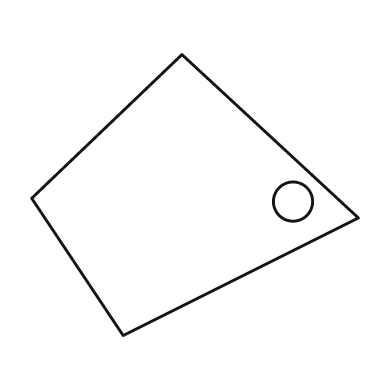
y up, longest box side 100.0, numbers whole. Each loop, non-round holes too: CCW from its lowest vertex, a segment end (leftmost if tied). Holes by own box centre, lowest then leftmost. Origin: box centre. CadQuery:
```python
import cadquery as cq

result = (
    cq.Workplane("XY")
    .moveTo(-22.0, -43.0)
    .lineTo(50.0, -7.0)
    .lineTo(-4.0, 43.0)
    .lineTo(-50.0, -1.0)
    .close()
    .moveTo(30.0, -2.0)
    .circle(6.0)
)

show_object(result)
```